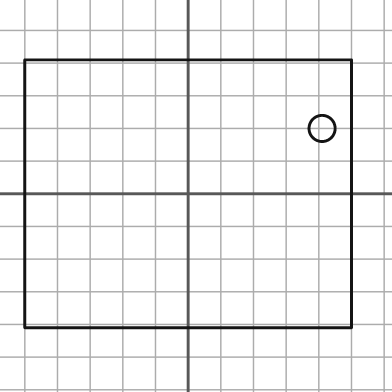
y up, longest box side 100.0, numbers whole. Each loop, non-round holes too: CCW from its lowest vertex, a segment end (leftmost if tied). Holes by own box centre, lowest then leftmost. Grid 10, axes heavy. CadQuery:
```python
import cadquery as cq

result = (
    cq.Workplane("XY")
    .moveTo(-50.0, -41.0)
    .lineTo(50.0, -41.0)
    .lineTo(50.0, 41.0)
    .lineTo(-50.0, 41.0)
    .close()
    .moveTo(41.0, 20.0)
    .circle(4.0)
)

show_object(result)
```